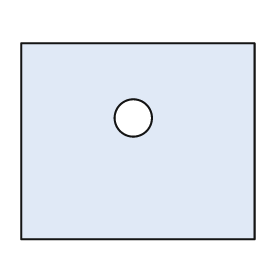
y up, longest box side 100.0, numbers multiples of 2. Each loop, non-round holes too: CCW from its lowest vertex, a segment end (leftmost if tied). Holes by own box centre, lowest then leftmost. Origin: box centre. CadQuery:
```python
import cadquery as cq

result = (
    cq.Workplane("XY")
    .moveTo(-50.0, -42.0)
    .lineTo(50.0, -42.0)
    .lineTo(50.0, 42.0)
    .lineTo(-50.0, 42.0)
    .close()
    .moveTo(-2.0, 10.0)
    .circle(8.0)
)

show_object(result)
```